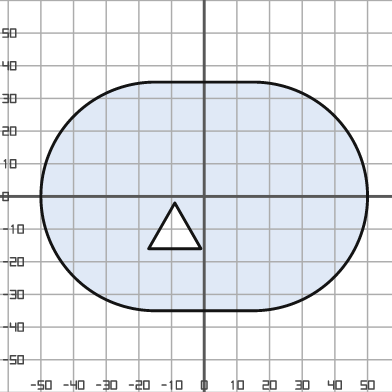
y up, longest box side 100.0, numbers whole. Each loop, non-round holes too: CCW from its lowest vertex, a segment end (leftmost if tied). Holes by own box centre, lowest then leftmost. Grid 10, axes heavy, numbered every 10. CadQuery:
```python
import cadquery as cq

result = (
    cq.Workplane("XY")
    .moveTo(-15.0, -35.0)
    .lineTo(15.0, -35.0)
    .threePointArc((50.0, 0.0), (15.0, 35.0))
    .lineTo(-15.0, 35.0)
    .threePointArc((-50.0, 0.0), (-15.0, -35.0))
    .close()
    .moveTo(-17.0, -16.0)
    .lineTo(-1.0, -16.0)
    .lineTo(-9.0, -2.0)
    .close()
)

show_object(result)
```